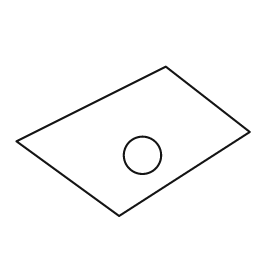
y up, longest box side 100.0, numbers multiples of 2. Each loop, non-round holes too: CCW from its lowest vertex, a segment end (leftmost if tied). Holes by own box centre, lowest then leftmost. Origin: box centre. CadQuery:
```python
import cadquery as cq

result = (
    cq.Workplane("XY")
    .moveTo(-6.0, -32.0)
    .lineTo(50.0, 4.0)
    .lineTo(14.0, 32.0)
    .lineTo(-50.0, 0.0)
    .close()
    .moveTo(4.0, -6.0)
    .circle(8.0)
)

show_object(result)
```